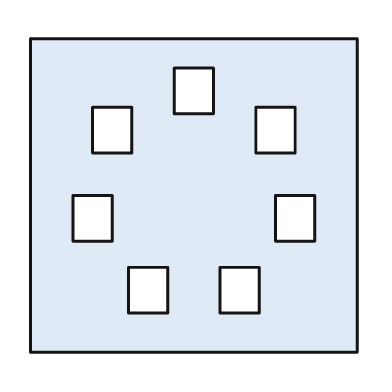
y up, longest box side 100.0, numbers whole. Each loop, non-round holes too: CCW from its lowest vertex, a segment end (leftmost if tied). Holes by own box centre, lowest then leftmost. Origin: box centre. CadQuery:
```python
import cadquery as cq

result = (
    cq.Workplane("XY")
    .moveTo(-50.0, -48.0)
    .lineTo(50.0, -48.0)
    .lineTo(50.0, 48.0)
    .lineTo(-50.0, 48.0)
    .close()
    .moveTo(-20.0, -36.0)
    .lineTo(-8.0, -36.0)
    .lineTo(-8.0, -22.0)
    .lineTo(-20.0, -22.0)
    .close()
    .moveTo(8.0, -36.0)
    .lineTo(20.0, -36.0)
    .lineTo(20.0, -22.0)
    .lineTo(8.0, -22.0)
    .close()
    .moveTo(-37.0, -14.0)
    .lineTo(-25.0, -14.0)
    .lineTo(-25.0, 0.0)
    .lineTo(-37.0, 0.0)
    .close()
    .moveTo(25.0, -14.0)
    .lineTo(37.0, -14.0)
    .lineTo(37.0, 0.0)
    .lineTo(25.0, 0.0)
    .close()
    .moveTo(-31.0, 13.0)
    .lineTo(-19.0, 13.0)
    .lineTo(-19.0, 27.0)
    .lineTo(-31.0, 27.0)
    .close()
    .moveTo(19.0, 13.0)
    .lineTo(31.0, 13.0)
    .lineTo(31.0, 27.0)
    .lineTo(19.0, 27.0)
    .close()
    .moveTo(-6.0, 25.0)
    .lineTo(6.0, 25.0)
    .lineTo(6.0, 39.0)
    .lineTo(-6.0, 39.0)
    .close()
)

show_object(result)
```